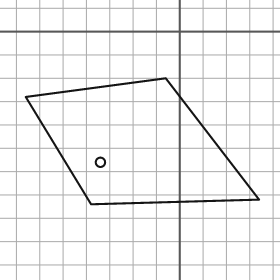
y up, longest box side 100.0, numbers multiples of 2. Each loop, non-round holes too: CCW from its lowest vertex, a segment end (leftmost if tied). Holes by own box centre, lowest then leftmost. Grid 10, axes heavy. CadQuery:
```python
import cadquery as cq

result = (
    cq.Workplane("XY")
    .moveTo(-38.0, -74.0)
    .lineTo(34.0, -72.0)
    .lineTo(-6.0, -20.0)
    .lineTo(-66.0, -28.0)
    .close()
    .moveTo(-34.0, -56.0)
    .circle(2.0)
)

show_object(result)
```